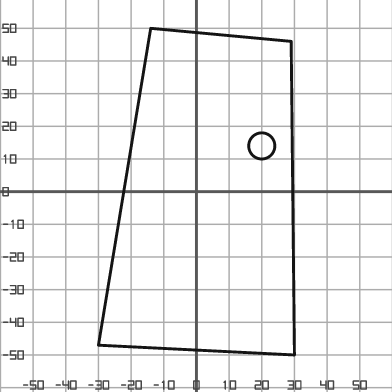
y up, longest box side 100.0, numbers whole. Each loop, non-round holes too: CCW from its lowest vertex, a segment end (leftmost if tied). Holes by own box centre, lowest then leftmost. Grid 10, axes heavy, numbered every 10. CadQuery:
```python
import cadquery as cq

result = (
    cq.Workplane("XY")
    .moveTo(30.0, -50.0)
    .lineTo(29.0, 46.0)
    .lineTo(-14.0, 50.0)
    .lineTo(-30.0, -47.0)
    .close()
    .moveTo(20.0, 14.0)
    .circle(4.0)
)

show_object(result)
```